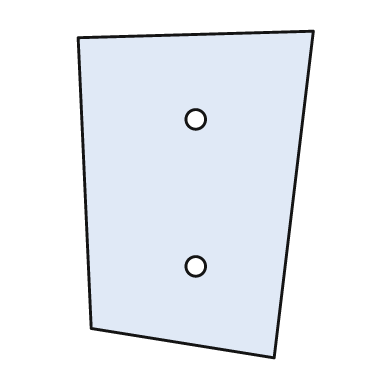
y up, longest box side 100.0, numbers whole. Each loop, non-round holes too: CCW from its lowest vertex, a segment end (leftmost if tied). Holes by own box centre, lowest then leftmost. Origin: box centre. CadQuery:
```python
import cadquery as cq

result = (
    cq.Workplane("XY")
    .moveTo(24.0, -50.0)
    .lineTo(36.0, 50.0)
    .lineTo(-36.0, 48.0)
    .lineTo(-32.0, -41.0)
    .close()
    .moveTo(0.0, -22.0)
    .circle(3.0)
    .moveTo(0.0, 23.0)
    .circle(3.0)
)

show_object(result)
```